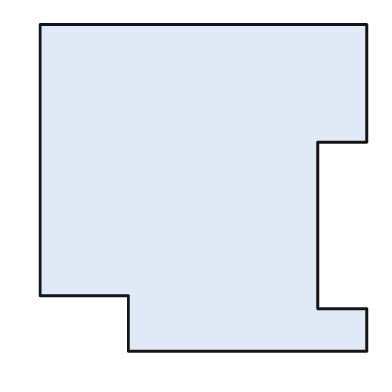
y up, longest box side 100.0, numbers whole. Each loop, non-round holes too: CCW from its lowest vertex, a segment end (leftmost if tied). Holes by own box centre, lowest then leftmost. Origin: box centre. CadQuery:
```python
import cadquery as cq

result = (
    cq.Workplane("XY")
    .moveTo(-23.0, -50.0)
    .lineTo(50.0, -50.0)
    .lineTo(50.0, -37.0)
    .lineTo(35.0, -37.0)
    .lineTo(35.0, 14.0)
    .lineTo(50.0, 14.0)
    .lineTo(50.0, 50.0)
    .lineTo(-50.0, 50.0)
    .lineTo(-50.0, -33.0)
    .lineTo(-23.0, -33.0)
    .close()
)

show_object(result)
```